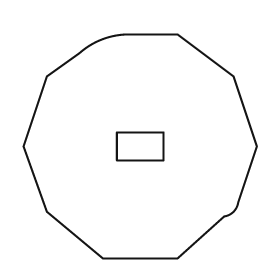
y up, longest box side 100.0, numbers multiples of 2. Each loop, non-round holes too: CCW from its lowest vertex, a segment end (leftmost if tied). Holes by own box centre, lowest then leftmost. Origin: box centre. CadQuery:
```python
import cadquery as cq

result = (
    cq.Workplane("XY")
    .moveTo(-16.0, -48.0)
    .lineTo(16.0, -48.0)
    .lineTo(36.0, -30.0)
    .threePointArc((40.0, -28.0), (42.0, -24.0))
    .lineTo(50.0, 0.0)
    .lineTo(40.0, 30.0)
    .lineTo(16.0, 48.0)
    .lineTo(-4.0, 48.0)
    .threePointArc((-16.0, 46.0), (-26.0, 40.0))
    .lineTo(-40.0, 30.0)
    .lineTo(-50.0, 0.0)
    .lineTo(-40.0, -28.0)
    .close()
    .moveTo(-10.0, -6.0)
    .lineTo(10.0, -6.0)
    .lineTo(10.0, 6.0)
    .lineTo(-10.0, 6.0)
    .close()
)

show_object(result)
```